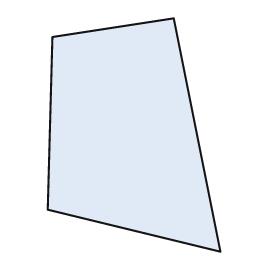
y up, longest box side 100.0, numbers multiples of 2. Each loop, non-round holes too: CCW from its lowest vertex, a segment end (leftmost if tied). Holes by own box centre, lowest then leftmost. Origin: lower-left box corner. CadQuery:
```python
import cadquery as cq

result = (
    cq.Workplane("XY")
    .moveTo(74.0, 0.0)
    .lineTo(54.0, 100.0)
    .lineTo(2.0, 92.0)
    .lineTo(0.0, 18.0)
    .close()
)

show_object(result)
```